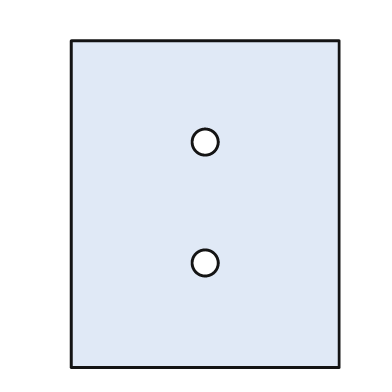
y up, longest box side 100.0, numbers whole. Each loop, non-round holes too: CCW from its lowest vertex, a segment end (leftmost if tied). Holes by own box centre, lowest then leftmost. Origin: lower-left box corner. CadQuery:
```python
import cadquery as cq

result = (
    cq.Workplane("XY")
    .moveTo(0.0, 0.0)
    .lineTo(82.0, 0.0)
    .lineTo(82.0, 100.0)
    .lineTo(0.0, 100.0)
    .close()
    .moveTo(41.0, 32.0)
    .circle(4.0)
    .moveTo(41.0, 69.0)
    .circle(4.0)
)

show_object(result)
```